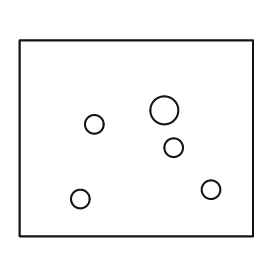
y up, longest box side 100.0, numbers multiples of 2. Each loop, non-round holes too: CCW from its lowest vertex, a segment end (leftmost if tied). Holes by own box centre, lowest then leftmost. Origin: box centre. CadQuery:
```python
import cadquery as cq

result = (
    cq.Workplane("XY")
    .moveTo(-50.0, -42.0)
    .lineTo(50.0, -42.0)
    .lineTo(50.0, 42.0)
    .lineTo(-50.0, 42.0)
    .close()
    .moveTo(-24.0, -26.0)
    .circle(4.0)
    .moveTo(32.0, -22.0)
    .circle(4.0)
    .moveTo(16.0, -4.0)
    .circle(4.0)
    .moveTo(-18.0, 6.0)
    .circle(4.0)
    .moveTo(12.0, 12.0)
    .circle(6.0)
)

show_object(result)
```